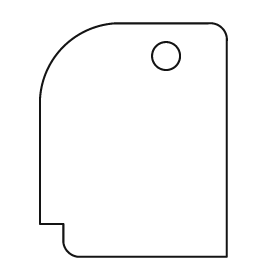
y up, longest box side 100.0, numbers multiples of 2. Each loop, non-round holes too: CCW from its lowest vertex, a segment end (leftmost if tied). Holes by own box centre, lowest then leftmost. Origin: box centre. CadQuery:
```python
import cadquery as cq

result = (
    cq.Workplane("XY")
    .moveTo(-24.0, -50.0)
    .lineTo(40.0, -50.0)
    .lineTo(40.0, 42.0)
    .threePointArc((38.0, 48.0), (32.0, 50.0))
    .lineTo(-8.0, 50.0)
    .threePointArc((-30.0, 40.0), (-40.0, 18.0))
    .lineTo(-40.0, -36.0)
    .lineTo(-30.0, -36.0)
    .lineTo(-30.0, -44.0)
    .threePointArc((-28.0, -48.0), (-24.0, -50.0))
    .close()
    .moveTo(14.0, 36.0)
    .circle(6.0)
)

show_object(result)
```